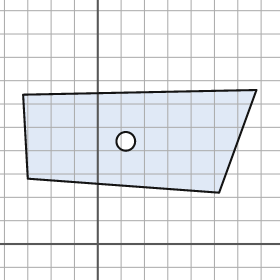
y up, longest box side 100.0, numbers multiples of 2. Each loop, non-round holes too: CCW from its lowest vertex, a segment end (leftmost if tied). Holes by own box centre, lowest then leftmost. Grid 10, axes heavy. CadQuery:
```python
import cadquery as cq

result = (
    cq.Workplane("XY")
    .moveTo(52.0, 22.0)
    .lineTo(68.0, 66.0)
    .lineTo(-32.0, 64.0)
    .lineTo(-30.0, 28.0)
    .close()
    .moveTo(12.0, 44.0)
    .circle(4.0)
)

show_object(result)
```